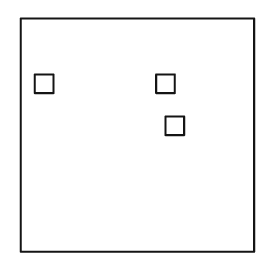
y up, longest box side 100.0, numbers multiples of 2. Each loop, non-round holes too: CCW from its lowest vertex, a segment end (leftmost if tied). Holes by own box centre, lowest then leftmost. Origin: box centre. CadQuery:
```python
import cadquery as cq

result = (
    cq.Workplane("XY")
    .moveTo(-50.0, -50.0)
    .lineTo(50.0, -50.0)
    .lineTo(50.0, 50.0)
    .lineTo(-50.0, 50.0)
    .close()
    .moveTo(12.0, 0.0)
    .lineTo(20.0, 0.0)
    .lineTo(20.0, 8.0)
    .lineTo(12.0, 8.0)
    .close()
    .moveTo(-44.0, 18.0)
    .lineTo(-36.0, 18.0)
    .lineTo(-36.0, 26.0)
    .lineTo(-44.0, 26.0)
    .close()
    .moveTo(8.0, 18.0)
    .lineTo(16.0, 18.0)
    .lineTo(16.0, 26.0)
    .lineTo(8.0, 26.0)
    .close()
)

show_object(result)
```